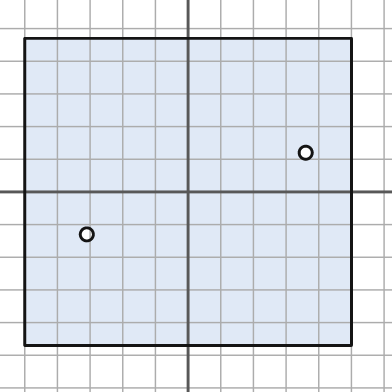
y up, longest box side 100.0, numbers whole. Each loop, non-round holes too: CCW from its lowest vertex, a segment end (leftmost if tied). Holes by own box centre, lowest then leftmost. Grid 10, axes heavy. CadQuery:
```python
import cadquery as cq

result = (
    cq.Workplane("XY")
    .moveTo(-50.0, -47.0)
    .lineTo(50.0, -47.0)
    .lineTo(50.0, 47.0)
    .lineTo(-50.0, 47.0)
    .close()
    .moveTo(-31.0, -13.0)
    .circle(2.0)
    .moveTo(36.0, 12.0)
    .circle(2.0)
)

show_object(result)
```